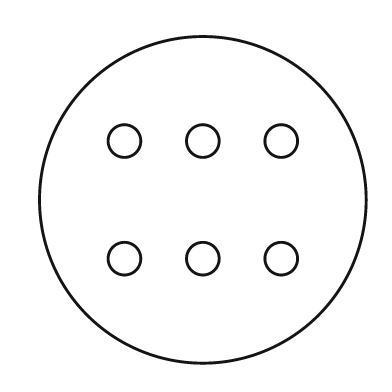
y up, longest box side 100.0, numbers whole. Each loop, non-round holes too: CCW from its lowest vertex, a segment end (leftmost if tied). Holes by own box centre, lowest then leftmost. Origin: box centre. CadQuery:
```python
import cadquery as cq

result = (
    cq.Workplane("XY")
    .moveTo(0.0, 0.0)
    .circle(50.0)
    .moveTo(-24.0, -18.0)
    .circle(5.0)
    .moveTo(0.0, -18.0)
    .circle(5.0)
    .moveTo(24.0, -18.0)
    .circle(5.0)
    .moveTo(-24.0, 18.0)
    .circle(5.0)
    .moveTo(0.0, 18.0)
    .circle(5.0)
    .moveTo(24.0, 18.0)
    .circle(5.0)
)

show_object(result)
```